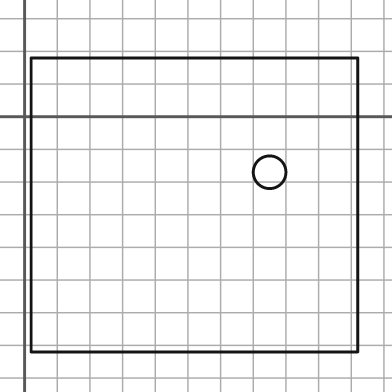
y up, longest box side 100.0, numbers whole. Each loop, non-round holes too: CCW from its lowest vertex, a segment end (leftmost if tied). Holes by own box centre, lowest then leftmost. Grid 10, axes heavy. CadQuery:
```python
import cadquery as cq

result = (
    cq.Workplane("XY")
    .moveTo(2.0, -72.0)
    .lineTo(102.0, -72.0)
    .lineTo(102.0, 18.0)
    .lineTo(2.0, 18.0)
    .close()
    .moveTo(75.0, -17.0)
    .circle(5.0)
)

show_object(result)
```